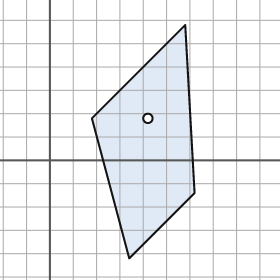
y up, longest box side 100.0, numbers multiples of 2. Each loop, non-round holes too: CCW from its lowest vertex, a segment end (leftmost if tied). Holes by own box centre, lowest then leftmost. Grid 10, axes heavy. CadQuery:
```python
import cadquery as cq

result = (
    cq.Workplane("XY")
    .moveTo(34.0, -42.0)
    .lineTo(62.0, -14.0)
    .lineTo(58.0, 58.0)
    .lineTo(18.0, 18.0)
    .close()
    .moveTo(42.0, 18.0)
    .circle(2.0)
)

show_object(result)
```